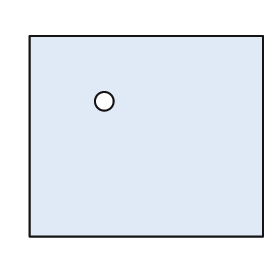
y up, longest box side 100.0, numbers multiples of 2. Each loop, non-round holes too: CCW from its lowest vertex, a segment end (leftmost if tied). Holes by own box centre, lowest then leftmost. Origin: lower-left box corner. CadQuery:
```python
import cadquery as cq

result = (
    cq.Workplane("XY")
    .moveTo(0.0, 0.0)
    .lineTo(100.0, 0.0)
    .lineTo(100.0, 86.0)
    .lineTo(0.0, 86.0)
    .close()
    .moveTo(32.0, 58.0)
    .circle(4.0)
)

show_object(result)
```